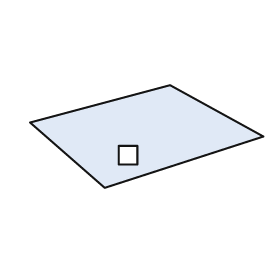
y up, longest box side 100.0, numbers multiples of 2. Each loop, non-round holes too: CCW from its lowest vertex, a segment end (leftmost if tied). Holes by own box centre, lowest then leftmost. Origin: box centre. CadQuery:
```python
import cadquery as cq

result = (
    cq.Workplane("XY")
    .moveTo(-18.0, -22.0)
    .lineTo(50.0, 0.0)
    .lineTo(10.0, 22.0)
    .lineTo(-50.0, 6.0)
    .close()
    .moveTo(-12.0, -12.0)
    .lineTo(-4.0, -12.0)
    .lineTo(-4.0, -4.0)
    .lineTo(-12.0, -4.0)
    .close()
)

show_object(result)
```